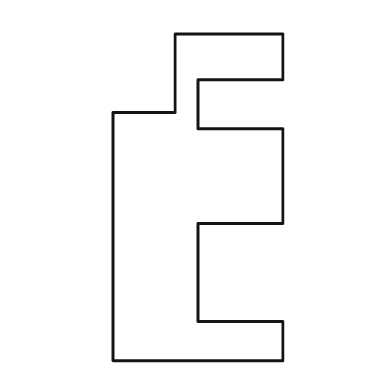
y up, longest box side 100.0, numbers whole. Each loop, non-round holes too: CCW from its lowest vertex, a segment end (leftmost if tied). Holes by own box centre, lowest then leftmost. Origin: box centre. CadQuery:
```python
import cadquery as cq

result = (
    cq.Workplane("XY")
    .moveTo(-26.0, -50.0)
    .lineTo(26.0, -50.0)
    .lineTo(26.0, -38.0)
    .lineTo(0.0, -38.0)
    .lineTo(0.0, -8.0)
    .lineTo(26.0, -8.0)
    .lineTo(26.0, 21.0)
    .lineTo(0.0, 21.0)
    .lineTo(0.0, 36.0)
    .lineTo(26.0, 36.0)
    .lineTo(26.0, 50.0)
    .lineTo(-7.0, 50.0)
    .lineTo(-7.0, 26.0)
    .lineTo(-26.0, 26.0)
    .close()
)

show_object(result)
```